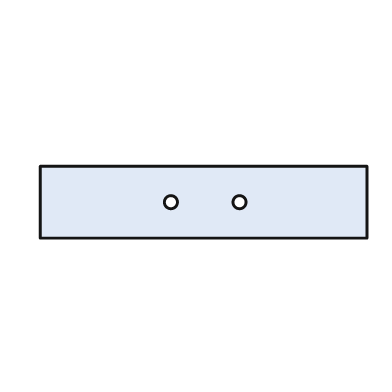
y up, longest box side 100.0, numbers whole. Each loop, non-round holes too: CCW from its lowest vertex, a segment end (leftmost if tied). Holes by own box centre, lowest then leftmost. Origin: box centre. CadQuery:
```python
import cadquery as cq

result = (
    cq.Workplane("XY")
    .moveTo(-50.0, -11.0)
    .lineTo(50.0, -11.0)
    .lineTo(50.0, 11.0)
    .lineTo(-50.0, 11.0)
    .close()
    .moveTo(-10.0, 0.0)
    .circle(2.0)
    .moveTo(11.0, 0.0)
    .circle(2.0)
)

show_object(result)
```